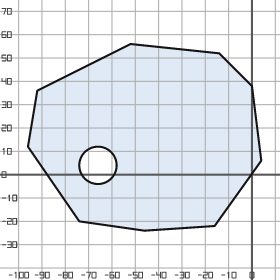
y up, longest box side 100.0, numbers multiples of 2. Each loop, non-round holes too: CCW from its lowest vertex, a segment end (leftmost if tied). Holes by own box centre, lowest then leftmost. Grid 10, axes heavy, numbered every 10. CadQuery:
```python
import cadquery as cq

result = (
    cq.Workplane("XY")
    .moveTo(-46.0, -24.0)
    .lineTo(-16.0, -22.0)
    .lineTo(4.0, 6.0)
    .lineTo(0.0, 38.0)
    .lineTo(-14.0, 52.0)
    .lineTo(-52.0, 56.0)
    .lineTo(-92.0, 36.0)
    .lineTo(-96.0, 12.0)
    .lineTo(-74.0, -20.0)
    .close()
    .moveTo(-66.0, 4.0)
    .circle(8.0)
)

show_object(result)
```